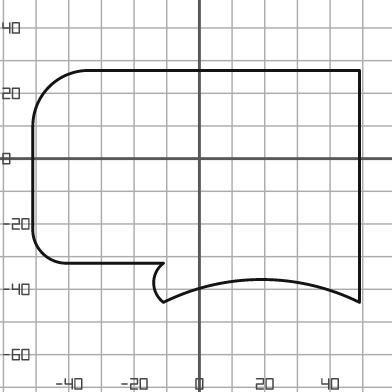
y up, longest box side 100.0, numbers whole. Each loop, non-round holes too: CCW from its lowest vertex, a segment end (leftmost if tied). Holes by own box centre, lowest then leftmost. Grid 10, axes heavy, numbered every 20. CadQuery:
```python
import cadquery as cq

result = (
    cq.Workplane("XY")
    .moveTo(-11.0, -44.0)
    .threePointArc((19.0, -37.0), (49.0, -44.0))
    .lineTo(49.0, 27.0)
    .lineTo(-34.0, 27.0)
    .threePointArc((-46.0, 22.0), (-51.0, 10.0))
    .lineTo(-51.0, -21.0)
    .threePointArc((-48.0, -29.0), (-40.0, -32.0))
    .lineTo(-11.0, -32.0)
    .threePointArc((-14.0, -38.0), (-11.0, -44.0))
    .close()
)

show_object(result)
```